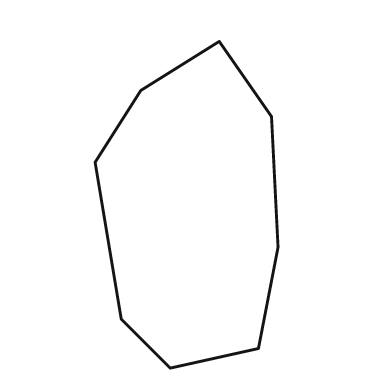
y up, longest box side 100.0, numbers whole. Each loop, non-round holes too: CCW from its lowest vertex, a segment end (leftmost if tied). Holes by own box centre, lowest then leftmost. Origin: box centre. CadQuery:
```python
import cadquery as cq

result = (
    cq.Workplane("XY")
    .moveTo(-5.0, -50.0)
    .lineTo(22.0, -44.0)
    .lineTo(28.0, -13.0)
    .lineTo(26.0, 27.0)
    .lineTo(10.0, 50.0)
    .lineTo(-14.0, 35.0)
    .lineTo(-28.0, 13.0)
    .lineTo(-20.0, -35.0)
    .close()
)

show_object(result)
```